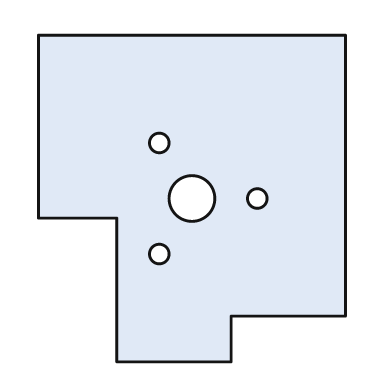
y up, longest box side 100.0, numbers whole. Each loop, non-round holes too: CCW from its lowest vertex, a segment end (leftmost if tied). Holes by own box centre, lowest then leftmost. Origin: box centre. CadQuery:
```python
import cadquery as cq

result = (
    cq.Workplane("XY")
    .moveTo(-23.0, -50.0)
    .lineTo(12.0, -50.0)
    .lineTo(12.0, -36.0)
    .lineTo(47.0, -36.0)
    .lineTo(47.0, 50.0)
    .lineTo(-47.0, 50.0)
    .lineTo(-47.0, -6.0)
    .lineTo(-23.0, -6.0)
    .close()
    .moveTo(-10.0, -17.0)
    .circle(3.0)
    .moveTo(0.0, 0.0)
    .circle(7.0)
    .moveTo(20.0, 0.0)
    .circle(3.0)
    .moveTo(-10.0, 17.0)
    .circle(3.0)
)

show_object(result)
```